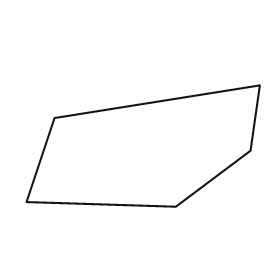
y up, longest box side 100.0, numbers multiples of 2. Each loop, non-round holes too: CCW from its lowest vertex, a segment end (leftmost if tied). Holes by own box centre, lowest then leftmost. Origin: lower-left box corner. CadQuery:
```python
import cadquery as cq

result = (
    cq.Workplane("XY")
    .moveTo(64.0, 0.0)
    .lineTo(96.0, 24.0)
    .lineTo(100.0, 52.0)
    .lineTo(12.0, 38.0)
    .lineTo(0.0, 2.0)
    .close()
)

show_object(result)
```